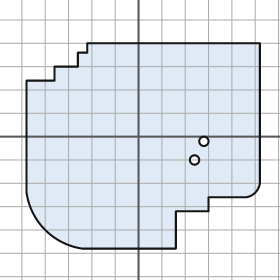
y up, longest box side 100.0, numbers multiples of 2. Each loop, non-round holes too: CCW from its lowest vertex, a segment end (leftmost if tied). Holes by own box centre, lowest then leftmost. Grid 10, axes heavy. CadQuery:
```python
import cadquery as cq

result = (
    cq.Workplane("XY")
    .moveTo(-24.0, -48.0)
    .lineTo(16.0, -48.0)
    .lineTo(16.0, -32.0)
    .lineTo(30.0, -32.0)
    .lineTo(30.0, -26.0)
    .lineTo(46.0, -26.0)
    .threePointArc((50.0, -24.0), (52.0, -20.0))
    .lineTo(52.0, 40.0)
    .lineTo(-22.0, 40.0)
    .lineTo(-22.0, 36.0)
    .lineTo(-26.0, 36.0)
    .lineTo(-26.0, 30.0)
    .lineTo(-36.0, 30.0)
    .lineTo(-36.0, 24.0)
    .lineTo(-48.0, 24.0)
    .lineTo(-48.0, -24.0)
    .threePointArc((-40.0, -40.0), (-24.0, -48.0))
    .close()
    .moveTo(24.0, -10.0)
    .circle(2.0)
    .moveTo(28.0, -2.0)
    .circle(2.0)
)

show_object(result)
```